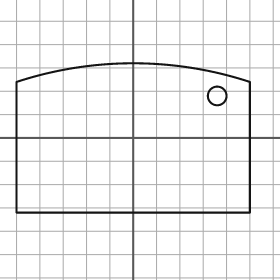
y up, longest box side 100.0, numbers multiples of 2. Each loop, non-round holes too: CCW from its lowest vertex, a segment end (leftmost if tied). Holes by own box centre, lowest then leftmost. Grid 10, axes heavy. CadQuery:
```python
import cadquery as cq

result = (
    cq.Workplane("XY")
    .moveTo(-50.0, -32.0)
    .lineTo(50.0, -32.0)
    .lineTo(50.0, 24.0)
    .threePointArc((0.0, 32.0), (-50.0, 24.0))
    .close()
    .moveTo(36.0, 18.0)
    .circle(4.0)
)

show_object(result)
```